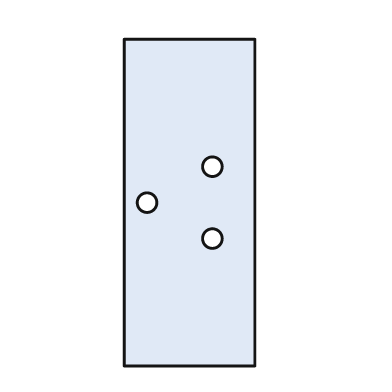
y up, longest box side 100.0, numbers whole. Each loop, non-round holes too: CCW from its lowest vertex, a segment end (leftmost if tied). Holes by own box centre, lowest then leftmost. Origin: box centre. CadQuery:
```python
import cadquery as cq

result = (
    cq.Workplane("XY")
    .moveTo(-20.0, -50.0)
    .lineTo(20.0, -50.0)
    .lineTo(20.0, 50.0)
    .lineTo(-20.0, 50.0)
    .close()
    .moveTo(7.0, -11.0)
    .circle(3.0)
    .moveTo(-13.0, 0.0)
    .circle(3.0)
    .moveTo(7.0, 11.0)
    .circle(3.0)
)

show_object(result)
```